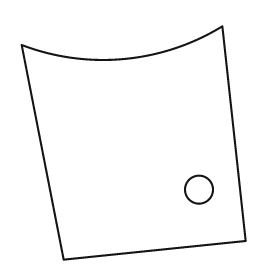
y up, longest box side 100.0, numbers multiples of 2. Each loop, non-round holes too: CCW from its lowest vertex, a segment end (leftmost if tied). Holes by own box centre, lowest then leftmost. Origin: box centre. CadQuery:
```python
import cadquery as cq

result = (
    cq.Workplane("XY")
    .moveTo(-30.0, -50.0)
    .lineTo(48.0, -42.0)
    .lineTo(38.0, 50.0)
    .threePointArc((-4.0, 36.0), (-48.0, 42.0))
    .close()
    .moveTo(28.0, -20.0)
    .circle(6.0)
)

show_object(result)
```